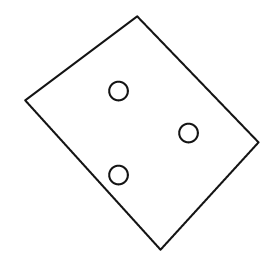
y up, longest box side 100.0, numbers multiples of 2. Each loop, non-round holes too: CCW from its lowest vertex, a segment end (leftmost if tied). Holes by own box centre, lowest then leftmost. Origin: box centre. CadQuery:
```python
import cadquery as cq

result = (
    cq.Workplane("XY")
    .moveTo(8.0, -50.0)
    .lineTo(50.0, -4.0)
    .lineTo(-2.0, 50.0)
    .lineTo(-50.0, 14.0)
    .close()
    .moveTo(-10.0, -18.0)
    .circle(4.0)
    .moveTo(20.0, 0.0)
    .circle(4.0)
    .moveTo(-10.0, 18.0)
    .circle(4.0)
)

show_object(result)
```